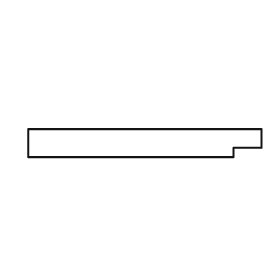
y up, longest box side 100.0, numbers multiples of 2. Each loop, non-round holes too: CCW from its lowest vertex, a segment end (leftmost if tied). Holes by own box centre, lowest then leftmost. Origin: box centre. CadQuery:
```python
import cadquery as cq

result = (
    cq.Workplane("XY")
    .moveTo(-50.0, -6.0)
    .lineTo(38.0, -6.0)
    .lineTo(38.0, -2.0)
    .lineTo(50.0, -2.0)
    .lineTo(50.0, 6.0)
    .lineTo(-50.0, 6.0)
    .close()
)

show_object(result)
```